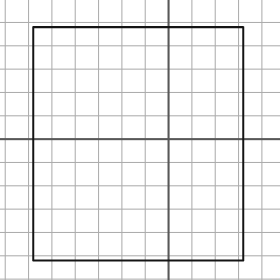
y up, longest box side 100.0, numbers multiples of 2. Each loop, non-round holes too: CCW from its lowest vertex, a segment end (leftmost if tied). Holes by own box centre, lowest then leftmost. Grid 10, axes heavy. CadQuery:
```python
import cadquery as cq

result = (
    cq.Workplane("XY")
    .moveTo(-58.0, -52.0)
    .lineTo(32.0, -52.0)
    .lineTo(32.0, 48.0)
    .lineTo(-58.0, 48.0)
    .close()
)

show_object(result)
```